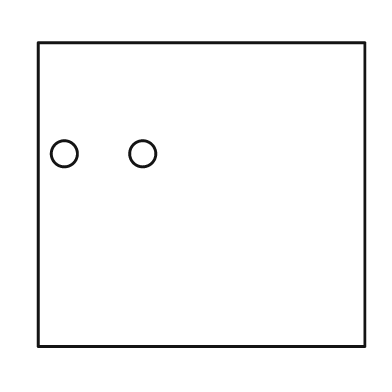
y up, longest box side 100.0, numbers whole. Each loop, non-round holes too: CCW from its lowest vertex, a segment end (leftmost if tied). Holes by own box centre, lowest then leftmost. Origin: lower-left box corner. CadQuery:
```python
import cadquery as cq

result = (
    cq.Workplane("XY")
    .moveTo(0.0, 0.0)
    .lineTo(100.0, 0.0)
    .lineTo(100.0, 93.0)
    .lineTo(0.0, 93.0)
    .close()
    .moveTo(8.0, 59.0)
    .circle(4.0)
    .moveTo(32.0, 59.0)
    .circle(4.0)
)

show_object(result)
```